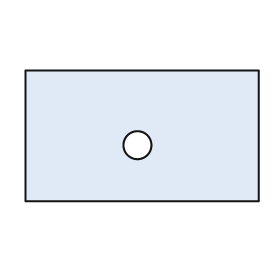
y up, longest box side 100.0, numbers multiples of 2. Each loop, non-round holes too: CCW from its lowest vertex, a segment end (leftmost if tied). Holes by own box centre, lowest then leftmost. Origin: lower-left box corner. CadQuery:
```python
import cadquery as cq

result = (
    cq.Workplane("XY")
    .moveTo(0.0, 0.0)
    .lineTo(100.0, 0.0)
    .lineTo(100.0, 56.0)
    .lineTo(0.0, 56.0)
    .close()
    .moveTo(48.0, 24.0)
    .circle(6.0)
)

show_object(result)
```